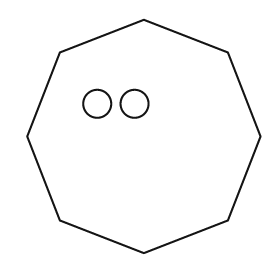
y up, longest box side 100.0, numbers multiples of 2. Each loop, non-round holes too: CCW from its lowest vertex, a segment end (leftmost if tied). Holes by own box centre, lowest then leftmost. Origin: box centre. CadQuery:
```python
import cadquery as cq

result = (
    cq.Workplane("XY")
    .moveTo(0.0, -50.0)
    .lineTo(36.0, -36.0)
    .lineTo(50.0, 0.0)
    .lineTo(36.0, 36.0)
    .lineTo(0.0, 50.0)
    .lineTo(-36.0, 36.0)
    .lineTo(-50.0, 0.0)
    .lineTo(-36.0, -36.0)
    .close()
    .moveTo(-20.0, 14.0)
    .circle(6.0)
    .moveTo(-4.0, 14.0)
    .circle(6.0)
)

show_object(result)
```